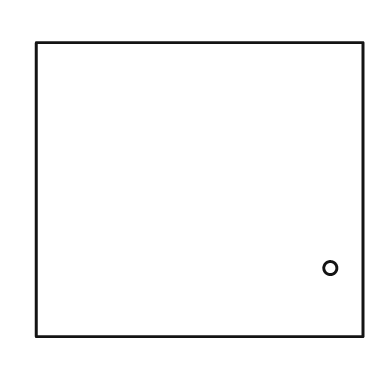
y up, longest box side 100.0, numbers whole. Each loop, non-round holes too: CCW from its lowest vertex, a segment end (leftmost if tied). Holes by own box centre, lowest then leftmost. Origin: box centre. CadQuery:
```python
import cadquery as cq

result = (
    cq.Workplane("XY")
    .moveTo(-50.0, -45.0)
    .lineTo(50.0, -45.0)
    .lineTo(50.0, 45.0)
    .lineTo(-50.0, 45.0)
    .close()
    .moveTo(40.0, -24.0)
    .circle(2.0)
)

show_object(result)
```